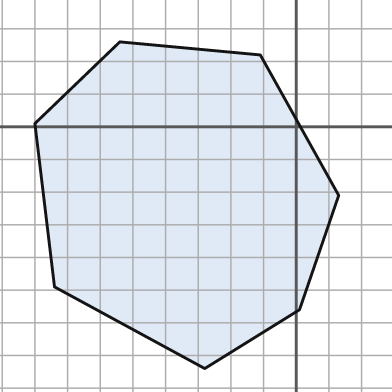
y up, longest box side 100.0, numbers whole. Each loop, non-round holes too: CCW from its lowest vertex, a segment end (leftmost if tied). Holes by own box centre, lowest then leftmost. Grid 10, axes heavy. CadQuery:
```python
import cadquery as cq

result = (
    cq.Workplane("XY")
    .moveTo(-28.0, -74.0)
    .lineTo(1.0, -56.0)
    .lineTo(13.0, -21.0)
    .lineTo(-11.0, 22.0)
    .lineTo(-54.0, 26.0)
    .lineTo(-80.0, 1.0)
    .lineTo(-74.0, -49.0)
    .close()
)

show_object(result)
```